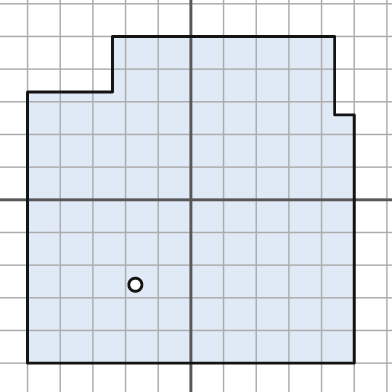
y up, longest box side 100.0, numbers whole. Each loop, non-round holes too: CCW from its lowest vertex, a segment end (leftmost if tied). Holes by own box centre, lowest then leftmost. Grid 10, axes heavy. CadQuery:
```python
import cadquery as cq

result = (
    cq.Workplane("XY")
    .moveTo(-50.0, -50.0)
    .lineTo(50.0, -50.0)
    .lineTo(50.0, 26.0)
    .lineTo(44.0, 26.0)
    .lineTo(44.0, 50.0)
    .lineTo(-24.0, 50.0)
    .lineTo(-24.0, 33.0)
    .lineTo(-50.0, 33.0)
    .close()
    .moveTo(-17.0, -26.0)
    .circle(2.0)
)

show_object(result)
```